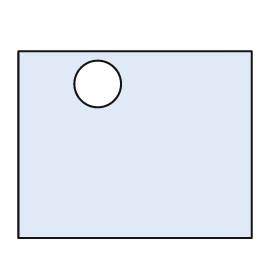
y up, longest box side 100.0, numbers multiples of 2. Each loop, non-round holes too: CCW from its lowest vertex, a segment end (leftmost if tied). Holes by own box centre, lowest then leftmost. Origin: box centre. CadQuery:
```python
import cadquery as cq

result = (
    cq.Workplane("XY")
    .moveTo(-50.0, -40.0)
    .lineTo(50.0, -40.0)
    .lineTo(50.0, 40.0)
    .lineTo(-50.0, 40.0)
    .close()
    .moveTo(-16.0, 26.0)
    .circle(10.0)
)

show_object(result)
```